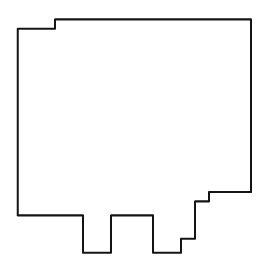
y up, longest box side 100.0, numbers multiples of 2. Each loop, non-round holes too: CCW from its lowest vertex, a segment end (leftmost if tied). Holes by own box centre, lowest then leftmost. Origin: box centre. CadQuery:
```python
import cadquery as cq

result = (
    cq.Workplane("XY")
    .moveTo(-22.0, -50.0)
    .lineTo(-10.0, -50.0)
    .lineTo(-10.0, -34.0)
    .lineTo(8.0, -34.0)
    .lineTo(8.0, -50.0)
    .lineTo(20.0, -50.0)
    .lineTo(20.0, -44.0)
    .lineTo(26.0, -44.0)
    .lineTo(26.0, -28.0)
    .lineTo(32.0, -28.0)
    .lineTo(32.0, -24.0)
    .lineTo(50.0, -24.0)
    .lineTo(50.0, 50.0)
    .lineTo(-34.0, 50.0)
    .lineTo(-34.0, 46.0)
    .lineTo(-50.0, 46.0)
    .lineTo(-50.0, -34.0)
    .lineTo(-22.0, -34.0)
    .close()
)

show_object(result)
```